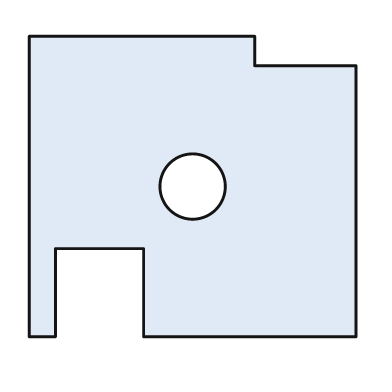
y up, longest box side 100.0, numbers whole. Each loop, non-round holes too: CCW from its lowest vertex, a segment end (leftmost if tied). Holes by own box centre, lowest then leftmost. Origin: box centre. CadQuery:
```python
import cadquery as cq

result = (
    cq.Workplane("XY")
    .moveTo(-50.0, -46.0)
    .lineTo(-42.0, -46.0)
    .lineTo(-42.0, -19.0)
    .lineTo(-15.0, -19.0)
    .lineTo(-15.0, -46.0)
    .lineTo(50.0, -46.0)
    .lineTo(50.0, 37.0)
    .lineTo(19.0, 37.0)
    .lineTo(19.0, 46.0)
    .lineTo(-50.0, 46.0)
    .close()
    .moveTo(0.0, 0.0)
    .circle(10.0)
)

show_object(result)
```